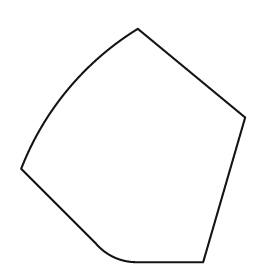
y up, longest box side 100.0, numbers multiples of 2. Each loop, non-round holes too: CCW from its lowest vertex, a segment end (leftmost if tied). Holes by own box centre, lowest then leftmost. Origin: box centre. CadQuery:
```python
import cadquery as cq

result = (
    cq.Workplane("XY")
    .moveTo(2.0, -50.0)
    .lineTo(30.0, -50.0)
    .lineTo(48.0, 12.0)
    .lineTo(2.0, 50.0)
    .threePointArc((-28.0, 24.0), (-48.0, -10.0))
    .lineTo(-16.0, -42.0)
    .threePointArc((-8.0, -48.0), (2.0, -50.0))
    .close()
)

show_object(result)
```